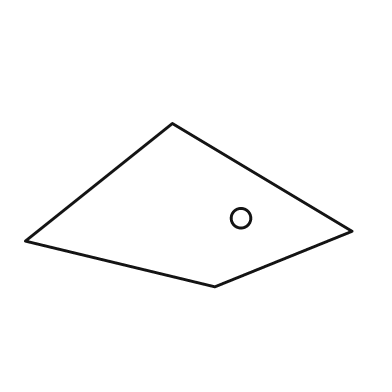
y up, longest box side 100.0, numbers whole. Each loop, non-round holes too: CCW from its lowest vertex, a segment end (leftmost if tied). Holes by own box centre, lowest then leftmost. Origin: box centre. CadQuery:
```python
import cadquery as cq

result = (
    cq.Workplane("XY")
    .moveTo(8.0, -25.0)
    .lineTo(50.0, -8.0)
    .lineTo(-5.0, 25.0)
    .lineTo(-50.0, -11.0)
    .close()
    .moveTo(16.0, -4.0)
    .circle(3.0)
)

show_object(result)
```